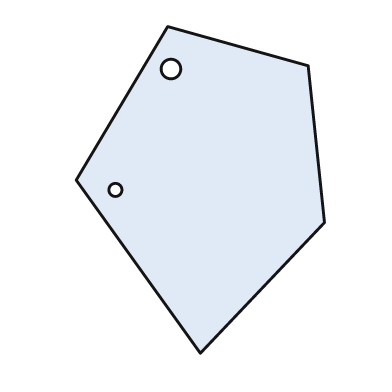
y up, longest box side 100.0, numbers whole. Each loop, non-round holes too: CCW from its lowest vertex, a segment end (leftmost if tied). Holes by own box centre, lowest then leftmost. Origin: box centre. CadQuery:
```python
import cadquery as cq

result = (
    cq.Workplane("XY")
    .moveTo(0.0, -50.0)
    .lineTo(38.0, -10.0)
    .lineTo(33.0, 38.0)
    .lineTo(-10.0, 50.0)
    .lineTo(-38.0, 3.0)
    .close()
    .moveTo(-26.0, 0.0)
    .circle(2.0)
    .moveTo(-9.0, 37.0)
    .circle(3.0)
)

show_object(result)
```